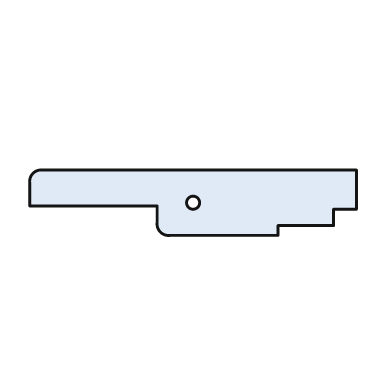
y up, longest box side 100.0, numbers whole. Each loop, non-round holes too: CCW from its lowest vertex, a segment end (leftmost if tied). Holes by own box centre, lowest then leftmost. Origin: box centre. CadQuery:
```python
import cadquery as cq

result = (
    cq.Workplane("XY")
    .moveTo(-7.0, -10.0)
    .lineTo(26.0, -10.0)
    .lineTo(26.0, -7.0)
    .lineTo(43.0, -7.0)
    .lineTo(43.0, -2.0)
    .lineTo(50.0, -2.0)
    .lineTo(50.0, 10.0)
    .lineTo(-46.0, 10.0)
    .threePointArc((-49.0, 9.0), (-50.0, 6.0))
    .lineTo(-50.0, -1.0)
    .lineTo(-11.0, -1.0)
    .lineTo(-11.0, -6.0)
    .threePointArc((-10.0, -9.0), (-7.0, -10.0))
    .close()
    .moveTo(0.0, 0.0)
    .circle(2.0)
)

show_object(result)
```